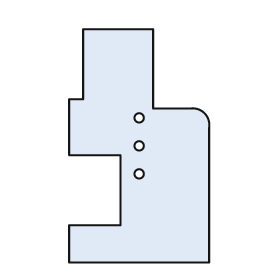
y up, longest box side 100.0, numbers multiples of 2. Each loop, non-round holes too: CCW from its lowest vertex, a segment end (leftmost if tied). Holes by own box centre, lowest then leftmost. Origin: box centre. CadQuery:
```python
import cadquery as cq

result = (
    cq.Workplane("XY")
    .moveTo(-30.0, -50.0)
    .lineTo(30.0, -50.0)
    .lineTo(30.0, 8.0)
    .threePointArc((28.0, 14.0), (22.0, 16.0))
    .lineTo(6.0, 16.0)
    .lineTo(6.0, 50.0)
    .lineTo(-24.0, 50.0)
    .lineTo(-24.0, 20.0)
    .lineTo(-30.0, 20.0)
    .lineTo(-30.0, -4.0)
    .lineTo(-8.0, -4.0)
    .lineTo(-8.0, -34.0)
    .lineTo(-30.0, -34.0)
    .close()
    .moveTo(0.0, -12.0)
    .circle(2.0)
    .moveTo(0.0, 0.0)
    .circle(2.0)
    .moveTo(0.0, 12.0)
    .circle(2.0)
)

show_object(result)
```